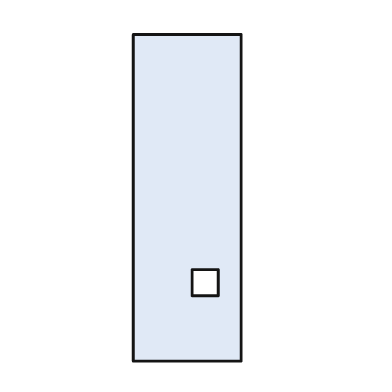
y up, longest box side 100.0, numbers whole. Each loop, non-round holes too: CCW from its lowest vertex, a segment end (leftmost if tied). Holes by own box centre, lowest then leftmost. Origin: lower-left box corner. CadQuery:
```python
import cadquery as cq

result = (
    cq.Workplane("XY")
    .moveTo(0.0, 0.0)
    .lineTo(33.0, 0.0)
    .lineTo(33.0, 100.0)
    .lineTo(0.0, 100.0)
    .close()
    .moveTo(18.0, 20.0)
    .lineTo(26.0, 20.0)
    .lineTo(26.0, 28.0)
    .lineTo(18.0, 28.0)
    .close()
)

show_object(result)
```